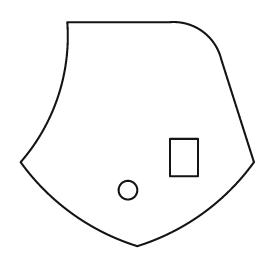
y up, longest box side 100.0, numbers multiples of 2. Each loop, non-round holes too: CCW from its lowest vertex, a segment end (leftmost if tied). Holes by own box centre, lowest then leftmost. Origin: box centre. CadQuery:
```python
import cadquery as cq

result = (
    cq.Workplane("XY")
    .moveTo(0.0, -48.0)
    .threePointArc((28.0, -34.0), (50.0, -12.0))
    .lineTo(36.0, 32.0)
    .threePointArc((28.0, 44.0), (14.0, 48.0))
    .lineTo(-30.0, 48.0)
    .threePointArc((-34.0, 16.0), (-50.0, -12.0))
    .threePointArc((-28.0, -34.0), (0.0, -48.0))
    .close()
    .moveTo(-4.0, -24.0)
    .circle(4.0)
    .moveTo(14.0, -18.0)
    .lineTo(26.0, -18.0)
    .lineTo(26.0, -2.0)
    .lineTo(14.0, -2.0)
    .close()
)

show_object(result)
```